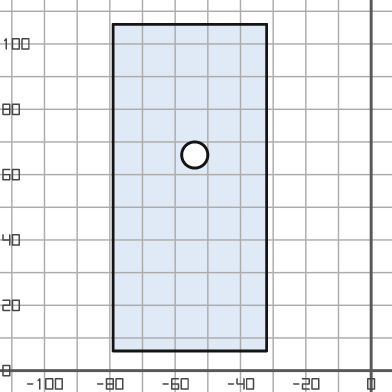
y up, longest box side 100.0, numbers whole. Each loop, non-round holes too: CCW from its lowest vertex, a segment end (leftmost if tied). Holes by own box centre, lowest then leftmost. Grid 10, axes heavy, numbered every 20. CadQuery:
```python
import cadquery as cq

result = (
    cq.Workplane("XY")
    .moveTo(-79.0, 6.0)
    .lineTo(-32.0, 6.0)
    .lineTo(-32.0, 106.0)
    .lineTo(-79.0, 106.0)
    .close()
    .moveTo(-54.0, 66.0)
    .circle(4.0)
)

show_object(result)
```